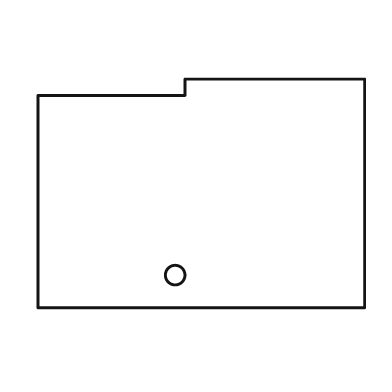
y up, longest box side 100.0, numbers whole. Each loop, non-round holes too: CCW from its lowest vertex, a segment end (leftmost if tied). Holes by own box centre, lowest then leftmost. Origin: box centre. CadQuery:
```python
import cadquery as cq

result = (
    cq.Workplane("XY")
    .moveTo(-50.0, -35.0)
    .lineTo(50.0, -35.0)
    .lineTo(50.0, 35.0)
    .lineTo(-5.0, 35.0)
    .lineTo(-5.0, 30.0)
    .lineTo(-50.0, 30.0)
    .close()
    .moveTo(-8.0, -25.0)
    .circle(3.0)
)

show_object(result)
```